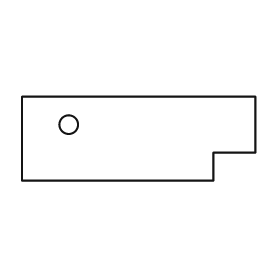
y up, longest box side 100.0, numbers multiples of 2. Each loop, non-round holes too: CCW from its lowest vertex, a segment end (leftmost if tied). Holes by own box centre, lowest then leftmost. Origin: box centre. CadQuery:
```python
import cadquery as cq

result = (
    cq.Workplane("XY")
    .moveTo(-50.0, -18.0)
    .lineTo(32.0, -18.0)
    .lineTo(32.0, -6.0)
    .lineTo(50.0, -6.0)
    .lineTo(50.0, 18.0)
    .lineTo(-50.0, 18.0)
    .close()
    .moveTo(-30.0, 6.0)
    .circle(4.0)
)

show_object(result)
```